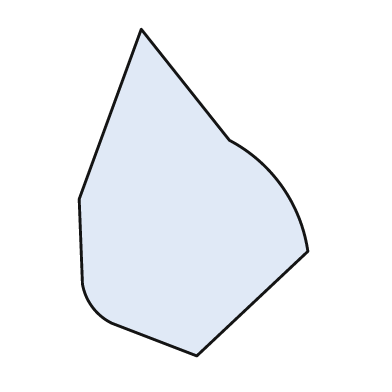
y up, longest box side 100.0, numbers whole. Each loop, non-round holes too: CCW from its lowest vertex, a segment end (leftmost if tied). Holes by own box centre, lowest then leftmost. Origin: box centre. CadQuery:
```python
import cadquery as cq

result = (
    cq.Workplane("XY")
    .moveTo(1.0, -50.0)
    .lineTo(35.0, -18.0)
    .threePointArc((27.0, 2.0), (11.0, 16.0))
    .lineTo(-16.0, 50.0)
    .lineTo(-35.0, -2.0)
    .lineTo(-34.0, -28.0)
    .threePointArc((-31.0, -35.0), (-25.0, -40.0))
    .close()
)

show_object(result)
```